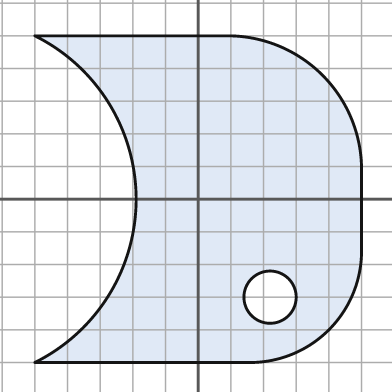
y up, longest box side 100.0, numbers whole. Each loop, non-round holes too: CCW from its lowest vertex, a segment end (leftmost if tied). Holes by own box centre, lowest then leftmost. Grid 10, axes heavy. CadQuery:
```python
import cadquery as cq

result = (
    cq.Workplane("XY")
    .moveTo(-50.0, -50.0)
    .lineTo(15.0, -50.0)
    .threePointArc((40.0, -40.0), (50.0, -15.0))
    .lineTo(50.0, 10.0)
    .threePointArc((38.0, 38.0), (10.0, 50.0))
    .lineTo(-50.0, 50.0)
    .threePointArc((-19.0, 0.0), (-50.0, -50.0))
    .close()
    .moveTo(22.0, -30.0)
    .circle(8.0)
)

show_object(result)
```